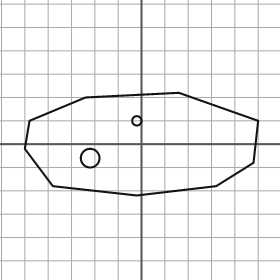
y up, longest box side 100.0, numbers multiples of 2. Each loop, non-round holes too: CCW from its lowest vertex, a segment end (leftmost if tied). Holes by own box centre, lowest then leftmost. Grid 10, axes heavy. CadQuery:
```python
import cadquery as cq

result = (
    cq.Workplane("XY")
    .moveTo(-2.0, -22.0)
    .lineTo(32.0, -18.0)
    .lineTo(48.0, -8.0)
    .lineTo(50.0, 10.0)
    .lineTo(16.0, 22.0)
    .lineTo(-24.0, 20.0)
    .lineTo(-48.0, 10.0)
    .lineTo(-50.0, -2.0)
    .lineTo(-38.0, -18.0)
    .close()
    .moveTo(-22.0, -6.0)
    .circle(4.0)
    .moveTo(-2.0, 10.0)
    .circle(2.0)
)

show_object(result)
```